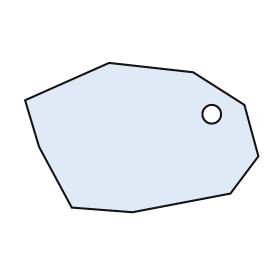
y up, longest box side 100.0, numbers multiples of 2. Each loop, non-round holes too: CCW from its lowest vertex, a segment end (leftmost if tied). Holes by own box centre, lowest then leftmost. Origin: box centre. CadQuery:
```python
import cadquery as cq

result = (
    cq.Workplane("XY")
    .moveTo(-4.0, -32.0)
    .lineTo(38.0, -24.0)
    .lineTo(50.0, -8.0)
    .lineTo(44.0, 14.0)
    .lineTo(22.0, 28.0)
    .lineTo(-14.0, 32.0)
    .lineTo(-50.0, 16.0)
    .lineTo(-44.0, -4.0)
    .lineTo(-30.0, -30.0)
    .close()
    .moveTo(30.0, 10.0)
    .circle(4.0)
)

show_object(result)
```